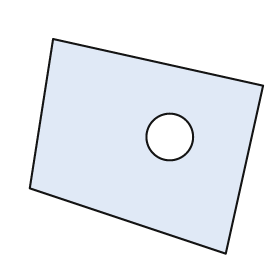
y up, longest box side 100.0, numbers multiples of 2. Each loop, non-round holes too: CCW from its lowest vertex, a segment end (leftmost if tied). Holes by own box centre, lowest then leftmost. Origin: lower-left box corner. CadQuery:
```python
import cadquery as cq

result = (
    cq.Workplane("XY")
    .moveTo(84.0, 0.0)
    .lineTo(100.0, 72.0)
    .lineTo(10.0, 92.0)
    .lineTo(0.0, 28.0)
    .close()
    .moveTo(60.0, 50.0)
    .circle(10.0)
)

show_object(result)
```